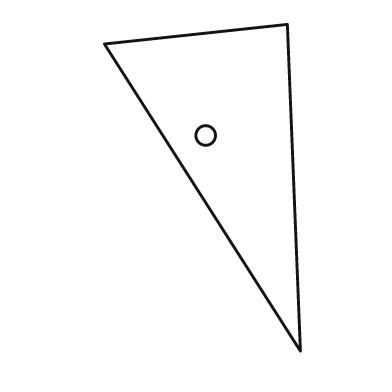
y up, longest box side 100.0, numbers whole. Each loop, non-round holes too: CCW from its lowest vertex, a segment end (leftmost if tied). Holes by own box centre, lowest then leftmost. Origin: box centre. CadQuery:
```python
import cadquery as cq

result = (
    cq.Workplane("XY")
    .moveTo(30.0, -50.0)
    .lineTo(26.0, 50.0)
    .lineTo(-30.0, 44.0)
    .close()
    .moveTo(1.0, 16.0)
    .circle(3.0)
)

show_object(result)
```